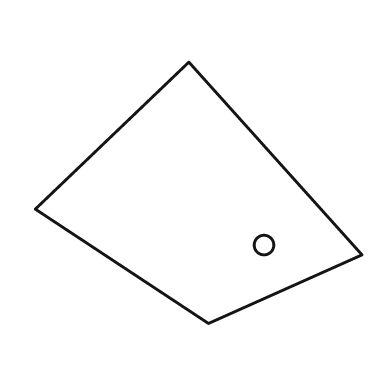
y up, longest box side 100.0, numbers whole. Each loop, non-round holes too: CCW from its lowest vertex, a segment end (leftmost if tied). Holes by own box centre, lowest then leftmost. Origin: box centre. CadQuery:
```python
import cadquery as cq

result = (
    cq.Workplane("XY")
    .moveTo(3.0, -40.0)
    .lineTo(50.0, -19.0)
    .lineTo(-3.0, 40.0)
    .lineTo(-50.0, -5.0)
    .close()
    .moveTo(20.0, -16.0)
    .circle(3.0)
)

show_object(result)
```